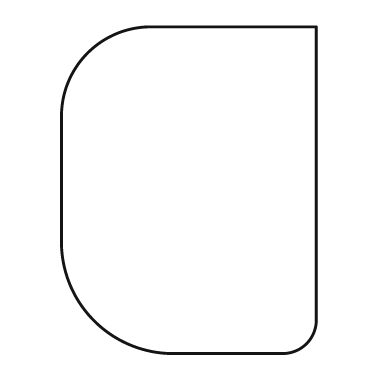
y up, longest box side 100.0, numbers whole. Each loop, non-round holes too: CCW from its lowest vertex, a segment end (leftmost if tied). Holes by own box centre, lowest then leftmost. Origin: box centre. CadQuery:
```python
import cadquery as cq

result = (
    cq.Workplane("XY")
    .moveTo(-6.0, -50.0)
    .lineTo(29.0, -50.0)
    .threePointArc((36.0, -47.0), (39.0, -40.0))
    .lineTo(39.0, 50.0)
    .lineTo(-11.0, 50.0)
    .threePointArc((-31.0, 42.0), (-39.0, 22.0))
    .lineTo(-39.0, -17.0)
    .threePointArc((-29.0, -40.0), (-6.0, -50.0))
    .close()
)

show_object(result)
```